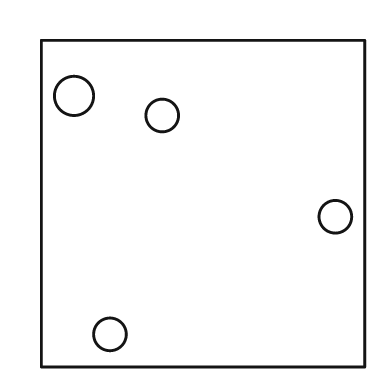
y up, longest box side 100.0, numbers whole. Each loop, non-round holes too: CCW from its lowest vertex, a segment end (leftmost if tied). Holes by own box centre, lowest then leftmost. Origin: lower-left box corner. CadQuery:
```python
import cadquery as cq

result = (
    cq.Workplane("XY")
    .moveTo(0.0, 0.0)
    .lineTo(99.0, 0.0)
    .lineTo(99.0, 100.0)
    .lineTo(0.0, 100.0)
    .close()
    .moveTo(21.0, 10.0)
    .circle(5.0)
    .moveTo(90.0, 46.0)
    .circle(5.0)
    .moveTo(37.0, 77.0)
    .circle(5.0)
    .moveTo(10.0, 83.0)
    .circle(6.0)
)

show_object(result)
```